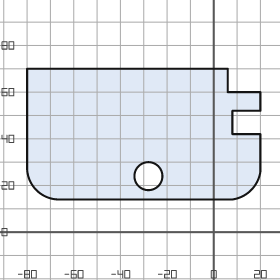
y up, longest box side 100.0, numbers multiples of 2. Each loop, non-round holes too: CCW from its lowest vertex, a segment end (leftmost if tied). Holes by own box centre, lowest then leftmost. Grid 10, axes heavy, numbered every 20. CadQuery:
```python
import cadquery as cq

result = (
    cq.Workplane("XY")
    .moveTo(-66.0, 14.0)
    .lineTo(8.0, 14.0)
    .threePointArc((16.0, 18.0), (20.0, 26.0))
    .lineTo(20.0, 42.0)
    .lineTo(8.0, 42.0)
    .lineTo(8.0, 52.0)
    .lineTo(20.0, 52.0)
    .lineTo(20.0, 60.0)
    .lineTo(6.0, 60.0)
    .lineTo(6.0, 70.0)
    .lineTo(-80.0, 70.0)
    .lineTo(-80.0, 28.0)
    .threePointArc((-76.0, 18.0), (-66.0, 14.0))
    .close()
    .moveTo(-28.0, 24.0)
    .circle(6.0)
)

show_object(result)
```